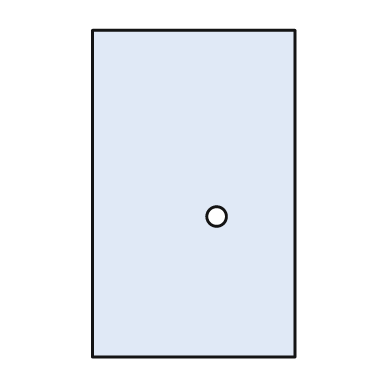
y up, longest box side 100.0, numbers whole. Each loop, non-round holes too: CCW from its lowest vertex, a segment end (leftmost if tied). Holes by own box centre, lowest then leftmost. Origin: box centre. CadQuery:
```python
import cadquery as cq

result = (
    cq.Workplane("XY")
    .moveTo(-31.0, -50.0)
    .lineTo(31.0, -50.0)
    .lineTo(31.0, 50.0)
    .lineTo(-31.0, 50.0)
    .close()
    .moveTo(7.0, -7.0)
    .circle(3.0)
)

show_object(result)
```